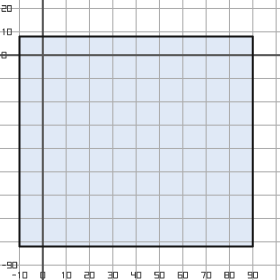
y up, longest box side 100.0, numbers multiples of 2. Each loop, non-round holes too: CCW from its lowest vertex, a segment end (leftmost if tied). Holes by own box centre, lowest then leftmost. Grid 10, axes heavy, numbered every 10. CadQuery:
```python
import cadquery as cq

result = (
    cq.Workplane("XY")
    .moveTo(-10.0, -82.0)
    .lineTo(90.0, -82.0)
    .lineTo(90.0, 8.0)
    .lineTo(-10.0, 8.0)
    .close()
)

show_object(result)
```